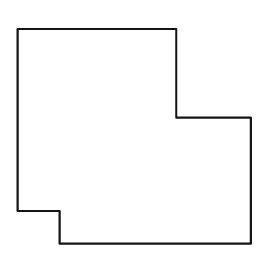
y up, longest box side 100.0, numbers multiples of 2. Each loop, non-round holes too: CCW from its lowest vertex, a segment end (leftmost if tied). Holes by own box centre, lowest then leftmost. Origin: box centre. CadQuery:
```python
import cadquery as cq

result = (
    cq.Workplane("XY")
    .moveTo(-32.0, -46.0)
    .lineTo(50.0, -46.0)
    .lineTo(50.0, 8.0)
    .lineTo(18.0, 8.0)
    .lineTo(18.0, 46.0)
    .lineTo(-50.0, 46.0)
    .lineTo(-50.0, -32.0)
    .lineTo(-32.0, -32.0)
    .close()
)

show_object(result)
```